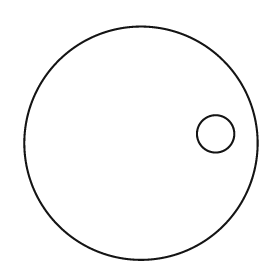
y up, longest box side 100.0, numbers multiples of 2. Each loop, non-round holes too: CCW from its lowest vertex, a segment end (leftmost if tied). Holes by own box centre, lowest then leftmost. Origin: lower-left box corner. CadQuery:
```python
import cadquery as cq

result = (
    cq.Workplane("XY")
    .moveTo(50.0, 50.0)
    .circle(50.0)
    .moveTo(82.0, 54.0)
    .circle(8.0)
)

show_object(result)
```